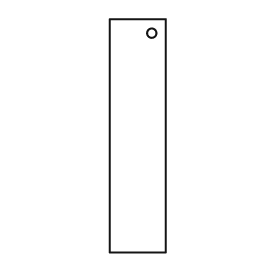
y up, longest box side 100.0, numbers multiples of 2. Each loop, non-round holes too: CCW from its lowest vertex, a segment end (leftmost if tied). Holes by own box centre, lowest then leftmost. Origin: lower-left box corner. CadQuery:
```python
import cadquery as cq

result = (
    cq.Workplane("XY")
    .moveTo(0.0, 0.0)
    .lineTo(24.0, 0.0)
    .lineTo(24.0, 100.0)
    .lineTo(0.0, 100.0)
    .close()
    .moveTo(18.0, 94.0)
    .circle(2.0)
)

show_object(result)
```